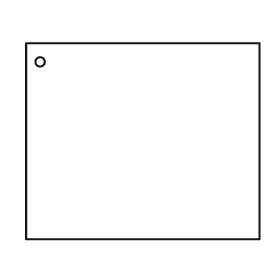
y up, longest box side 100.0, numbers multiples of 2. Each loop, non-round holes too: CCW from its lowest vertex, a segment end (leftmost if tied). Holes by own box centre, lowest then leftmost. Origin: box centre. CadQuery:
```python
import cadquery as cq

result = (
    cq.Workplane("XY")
    .moveTo(-50.0, -42.0)
    .lineTo(50.0, -42.0)
    .lineTo(50.0, 42.0)
    .lineTo(-50.0, 42.0)
    .close()
    .moveTo(-44.0, 34.0)
    .circle(2.0)
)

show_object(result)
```